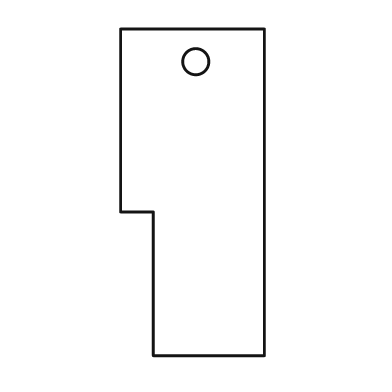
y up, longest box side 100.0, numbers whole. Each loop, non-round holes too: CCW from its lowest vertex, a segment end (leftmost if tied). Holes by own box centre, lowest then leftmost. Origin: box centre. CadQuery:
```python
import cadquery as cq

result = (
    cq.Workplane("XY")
    .moveTo(-12.0, -50.0)
    .lineTo(22.0, -50.0)
    .lineTo(22.0, 50.0)
    .lineTo(-22.0, 50.0)
    .lineTo(-22.0, -6.0)
    .lineTo(-12.0, -6.0)
    .close()
    .moveTo(1.0, 40.0)
    .circle(4.0)
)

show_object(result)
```